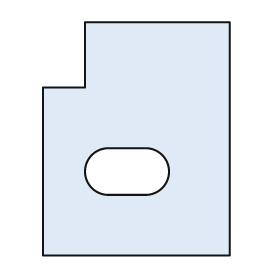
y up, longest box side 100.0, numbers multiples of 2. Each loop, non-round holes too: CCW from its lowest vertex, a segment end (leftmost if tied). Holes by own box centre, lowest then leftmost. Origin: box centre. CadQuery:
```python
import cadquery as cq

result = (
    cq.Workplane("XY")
    .moveTo(-40.0, -50.0)
    .lineTo(40.0, -50.0)
    .lineTo(40.0, 50.0)
    .lineTo(-22.0, 50.0)
    .lineTo(-22.0, 22.0)
    .lineTo(-40.0, 22.0)
    .close()
    .moveTo(-12.0, -24.0)
    .lineTo(4.0, -24.0)
    .threePointArc((14.0, -14.0), (4.0, -4.0))
    .lineTo(-12.0, -4.0)
    .threePointArc((-22.0, -14.0), (-12.0, -24.0))
    .close()
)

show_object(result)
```